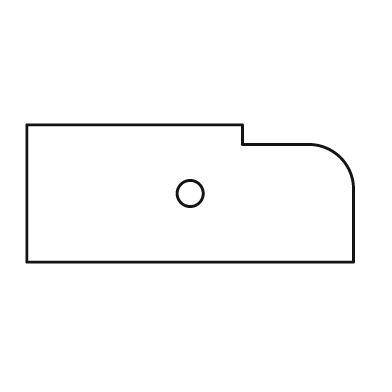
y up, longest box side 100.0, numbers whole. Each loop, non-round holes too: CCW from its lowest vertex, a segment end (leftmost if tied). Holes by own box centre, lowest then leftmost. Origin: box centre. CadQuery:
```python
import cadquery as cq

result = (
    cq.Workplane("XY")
    .moveTo(-50.0, -21.0)
    .lineTo(50.0, -21.0)
    .lineTo(50.0, 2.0)
    .threePointArc((46.0, 11.0), (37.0, 15.0))
    .lineTo(16.0, 15.0)
    .lineTo(16.0, 21.0)
    .lineTo(-50.0, 21.0)
    .close()
    .moveTo(0.0, 0.0)
    .circle(4.0)
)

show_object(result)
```